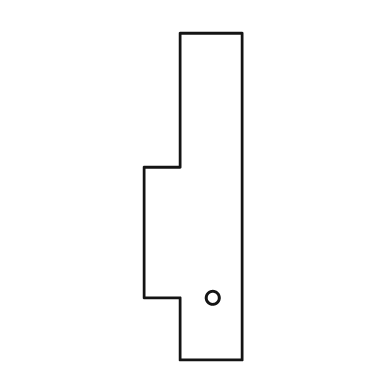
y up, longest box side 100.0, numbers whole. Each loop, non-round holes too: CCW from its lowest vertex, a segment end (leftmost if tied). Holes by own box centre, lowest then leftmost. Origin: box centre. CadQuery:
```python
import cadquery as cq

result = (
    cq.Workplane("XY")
    .moveTo(-4.0, -50.0)
    .lineTo(15.0, -50.0)
    .lineTo(15.0, 50.0)
    .lineTo(-4.0, 50.0)
    .lineTo(-4.0, 9.0)
    .lineTo(-15.0, 9.0)
    .lineTo(-15.0, -31.0)
    .lineTo(-4.0, -31.0)
    .close()
    .moveTo(6.0, -31.0)
    .circle(2.0)
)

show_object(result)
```